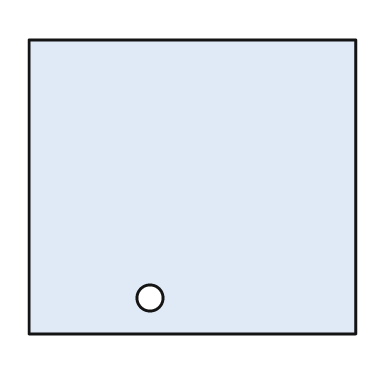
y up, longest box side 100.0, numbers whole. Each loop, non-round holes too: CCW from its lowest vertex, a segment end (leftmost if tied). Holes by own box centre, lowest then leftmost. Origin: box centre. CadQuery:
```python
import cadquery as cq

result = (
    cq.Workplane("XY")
    .moveTo(-50.0, -45.0)
    .lineTo(50.0, -45.0)
    .lineTo(50.0, 45.0)
    .lineTo(-50.0, 45.0)
    .close()
    .moveTo(-13.0, -34.0)
    .circle(4.0)
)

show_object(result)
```